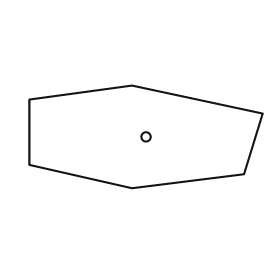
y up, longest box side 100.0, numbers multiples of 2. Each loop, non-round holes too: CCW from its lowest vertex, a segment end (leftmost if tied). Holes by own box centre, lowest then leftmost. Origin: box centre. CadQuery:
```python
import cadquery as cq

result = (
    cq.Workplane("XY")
    .moveTo(-6.0, -22.0)
    .lineTo(42.0, -16.0)
    .lineTo(50.0, 10.0)
    .lineTo(-6.0, 22.0)
    .lineTo(-50.0, 16.0)
    .lineTo(-50.0, -12.0)
    .close()
    .moveTo(0.0, 0.0)
    .circle(2.0)
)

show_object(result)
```